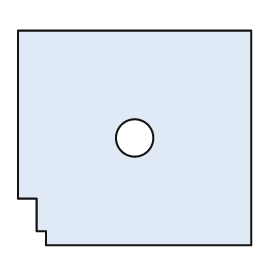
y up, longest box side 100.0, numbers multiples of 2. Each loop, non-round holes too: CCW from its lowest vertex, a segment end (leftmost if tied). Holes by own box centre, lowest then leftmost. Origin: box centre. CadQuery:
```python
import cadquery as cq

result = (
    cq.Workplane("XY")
    .moveTo(-38.0, -46.0)
    .lineTo(50.0, -46.0)
    .lineTo(50.0, 46.0)
    .lineTo(-50.0, 46.0)
    .lineTo(-50.0, -26.0)
    .lineTo(-42.0, -26.0)
    .lineTo(-42.0, -40.0)
    .lineTo(-38.0, -40.0)
    .close()
    .moveTo(0.0, 0.0)
    .circle(8.0)
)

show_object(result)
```